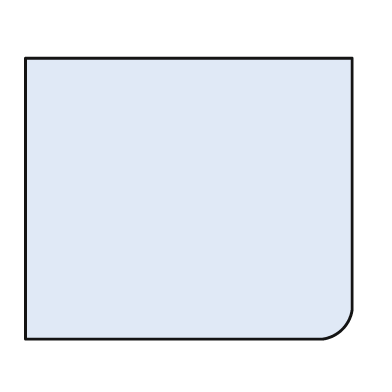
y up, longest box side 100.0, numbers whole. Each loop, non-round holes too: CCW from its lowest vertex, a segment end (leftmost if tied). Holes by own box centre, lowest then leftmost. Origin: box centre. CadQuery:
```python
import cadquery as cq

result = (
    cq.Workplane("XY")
    .moveTo(-50.0, -43.0)
    .lineTo(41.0, -43.0)
    .threePointArc((47.0, -40.0), (50.0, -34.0))
    .lineTo(50.0, 43.0)
    .lineTo(-50.0, 43.0)
    .close()
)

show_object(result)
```